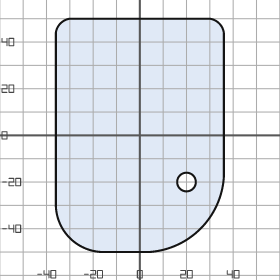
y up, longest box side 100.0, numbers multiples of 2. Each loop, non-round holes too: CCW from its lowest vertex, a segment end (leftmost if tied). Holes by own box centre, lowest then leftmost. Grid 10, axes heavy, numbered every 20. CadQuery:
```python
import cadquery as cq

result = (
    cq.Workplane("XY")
    .moveTo(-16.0, -50.0)
    .lineTo(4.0, -50.0)
    .threePointArc((26.0, -40.0), (36.0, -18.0))
    .lineTo(36.0, 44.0)
    .threePointArc((34.0, 48.0), (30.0, 50.0))
    .lineTo(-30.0, 50.0)
    .threePointArc((-34.0, 48.0), (-36.0, 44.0))
    .lineTo(-36.0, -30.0)
    .threePointArc((-30.0, -44.0), (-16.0, -50.0))
    .close()
    .moveTo(20.0, -20.0)
    .circle(4.0)
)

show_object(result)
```